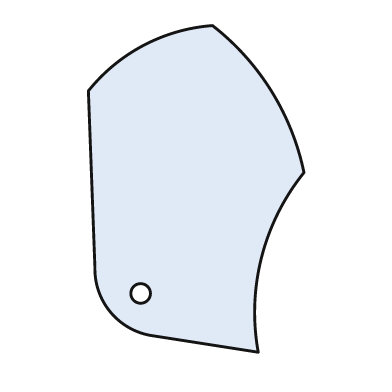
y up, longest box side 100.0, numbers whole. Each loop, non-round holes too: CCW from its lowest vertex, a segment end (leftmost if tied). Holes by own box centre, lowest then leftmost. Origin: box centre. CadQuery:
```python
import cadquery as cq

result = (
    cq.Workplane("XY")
    .moveTo(19.0, -50.0)
    .threePointArc((20.0, -21.0), (33.0, 5.0))
    .threePointArc((23.0, 30.0), (5.0, 50.0))
    .threePointArc((-16.0, 44.0), (-33.0, 30.0))
    .lineTo(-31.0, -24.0)
    .threePointArc((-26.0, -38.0), (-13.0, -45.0))
    .close()
    .moveTo(-17.0, -32.0)
    .circle(3.0)
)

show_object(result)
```